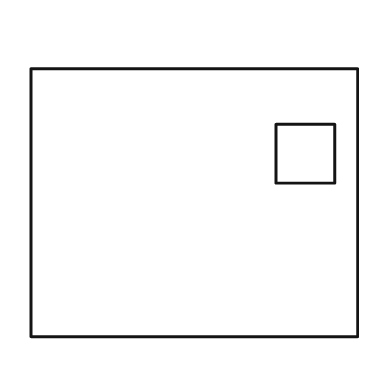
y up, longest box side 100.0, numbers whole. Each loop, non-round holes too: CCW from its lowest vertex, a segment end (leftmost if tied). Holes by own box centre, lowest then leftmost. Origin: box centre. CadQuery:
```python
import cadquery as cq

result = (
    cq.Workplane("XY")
    .moveTo(-50.0, -41.0)
    .lineTo(50.0, -41.0)
    .lineTo(50.0, 41.0)
    .lineTo(-50.0, 41.0)
    .close()
    .moveTo(25.0, 6.0)
    .lineTo(43.0, 6.0)
    .lineTo(43.0, 24.0)
    .lineTo(25.0, 24.0)
    .close()
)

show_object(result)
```